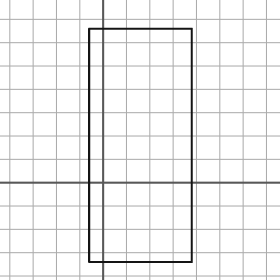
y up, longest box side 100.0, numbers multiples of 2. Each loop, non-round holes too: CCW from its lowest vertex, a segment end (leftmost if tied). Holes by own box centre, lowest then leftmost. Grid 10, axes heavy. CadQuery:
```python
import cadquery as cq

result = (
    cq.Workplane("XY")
    .moveTo(-6.0, -34.0)
    .lineTo(38.0, -34.0)
    .lineTo(38.0, 66.0)
    .lineTo(-6.0, 66.0)
    .close()
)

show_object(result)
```